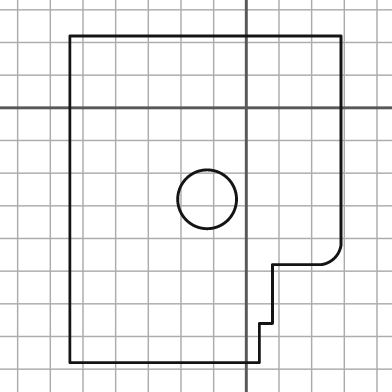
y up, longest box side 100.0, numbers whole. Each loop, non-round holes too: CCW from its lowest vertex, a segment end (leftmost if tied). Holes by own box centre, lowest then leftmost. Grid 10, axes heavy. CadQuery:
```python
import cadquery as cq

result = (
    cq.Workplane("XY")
    .moveTo(-54.0, -78.0)
    .lineTo(4.0, -78.0)
    .lineTo(4.0, -66.0)
    .lineTo(8.0, -66.0)
    .lineTo(8.0, -48.0)
    .lineTo(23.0, -48.0)
    .threePointArc((27.0, -46.0), (29.0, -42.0))
    .lineTo(29.0, 22.0)
    .lineTo(-54.0, 22.0)
    .close()
    .moveTo(-12.0, -28.0)
    .circle(9.0)
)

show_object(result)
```